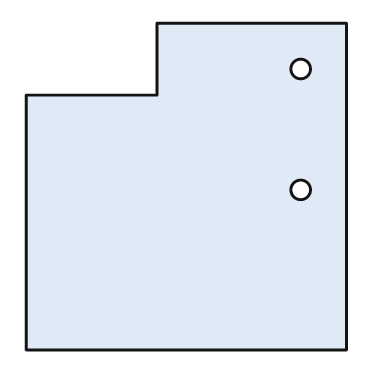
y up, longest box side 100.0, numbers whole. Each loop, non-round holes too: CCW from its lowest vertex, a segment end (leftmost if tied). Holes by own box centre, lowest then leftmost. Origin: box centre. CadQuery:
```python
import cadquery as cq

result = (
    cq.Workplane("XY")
    .moveTo(-49.0, -50.0)
    .lineTo(49.0, -50.0)
    .lineTo(49.0, 50.0)
    .lineTo(-9.0, 50.0)
    .lineTo(-9.0, 28.0)
    .lineTo(-49.0, 28.0)
    .close()
    .moveTo(35.0, -1.0)
    .circle(3.0)
    .moveTo(35.0, 36.0)
    .circle(3.0)
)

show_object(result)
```